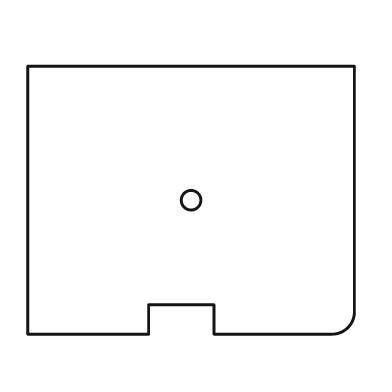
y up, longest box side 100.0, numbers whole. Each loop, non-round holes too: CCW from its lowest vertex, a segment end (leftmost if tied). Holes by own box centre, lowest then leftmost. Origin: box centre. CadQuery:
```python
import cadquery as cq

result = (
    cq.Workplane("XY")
    .moveTo(-50.0, -41.0)
    .lineTo(-13.0, -41.0)
    .lineTo(-13.0, -32.0)
    .lineTo(7.0, -32.0)
    .lineTo(7.0, -41.0)
    .lineTo(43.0, -41.0)
    .threePointArc((48.0, -39.0), (50.0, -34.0))
    .lineTo(50.0, 41.0)
    .lineTo(-50.0, 41.0)
    .close()
    .moveTo(0.0, 0.0)
    .circle(3.0)
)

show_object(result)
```